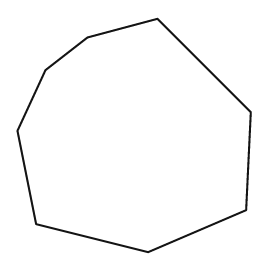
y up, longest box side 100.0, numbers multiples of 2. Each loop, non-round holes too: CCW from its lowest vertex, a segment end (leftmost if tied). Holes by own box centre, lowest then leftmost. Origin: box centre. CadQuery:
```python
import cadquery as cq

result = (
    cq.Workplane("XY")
    .moveTo(6.0, -50.0)
    .lineTo(48.0, -32.0)
    .lineTo(50.0, 10.0)
    .lineTo(10.0, 50.0)
    .lineTo(-20.0, 42.0)
    .lineTo(-38.0, 28.0)
    .lineTo(-50.0, 2.0)
    .lineTo(-42.0, -38.0)
    .close()
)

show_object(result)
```